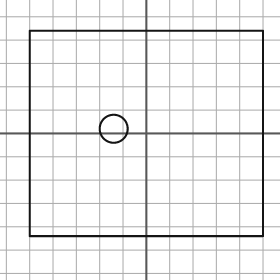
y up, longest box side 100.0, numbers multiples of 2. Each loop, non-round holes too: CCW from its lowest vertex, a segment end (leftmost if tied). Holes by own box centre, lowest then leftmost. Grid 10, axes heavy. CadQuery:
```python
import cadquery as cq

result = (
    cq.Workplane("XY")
    .moveTo(-50.0, -44.0)
    .lineTo(50.0, -44.0)
    .lineTo(50.0, 44.0)
    .lineTo(-50.0, 44.0)
    .close()
    .moveTo(-14.0, 2.0)
    .circle(6.0)
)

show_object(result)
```